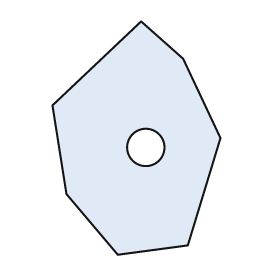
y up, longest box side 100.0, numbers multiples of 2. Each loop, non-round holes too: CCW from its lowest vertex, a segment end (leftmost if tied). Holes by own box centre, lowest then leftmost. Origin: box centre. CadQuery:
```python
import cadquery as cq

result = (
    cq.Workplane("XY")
    .moveTo(-8.0, -50.0)
    .lineTo(22.0, -46.0)
    .lineTo(36.0, 0.0)
    .lineTo(20.0, 34.0)
    .lineTo(2.0, 50.0)
    .lineTo(-36.0, 14.0)
    .lineTo(-30.0, -24.0)
    .close()
    .moveTo(4.0, -4.0)
    .circle(8.0)
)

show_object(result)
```